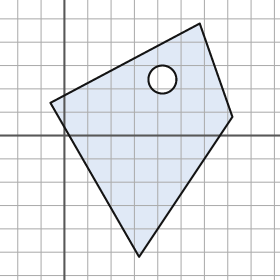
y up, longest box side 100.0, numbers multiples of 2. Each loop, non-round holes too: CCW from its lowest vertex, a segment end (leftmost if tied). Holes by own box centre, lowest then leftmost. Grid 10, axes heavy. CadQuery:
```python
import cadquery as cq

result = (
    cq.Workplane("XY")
    .moveTo(32.0, -52.0)
    .lineTo(72.0, 8.0)
    .lineTo(58.0, 48.0)
    .lineTo(-6.0, 14.0)
    .close()
    .moveTo(42.0, 24.0)
    .circle(6.0)
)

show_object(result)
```